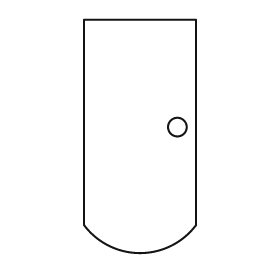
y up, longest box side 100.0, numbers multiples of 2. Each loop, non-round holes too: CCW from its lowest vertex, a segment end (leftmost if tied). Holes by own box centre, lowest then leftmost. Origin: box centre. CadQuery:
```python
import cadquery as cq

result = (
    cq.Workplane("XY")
    .moveTo(-24.0, -38.0)
    .threePointArc((0.0, -50.0), (24.0, -38.0))
    .lineTo(24.0, 50.0)
    .lineTo(-24.0, 50.0)
    .close()
    .moveTo(16.0, 4.0)
    .circle(4.0)
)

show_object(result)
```